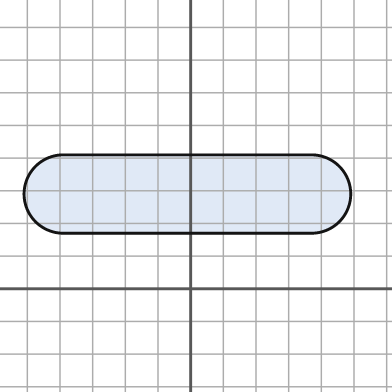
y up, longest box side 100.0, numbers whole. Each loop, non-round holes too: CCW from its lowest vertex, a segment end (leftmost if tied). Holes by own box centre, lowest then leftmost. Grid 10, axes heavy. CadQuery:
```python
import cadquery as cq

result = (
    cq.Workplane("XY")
    .moveTo(-39.0, 17.0)
    .lineTo(37.0, 17.0)
    .threePointArc((49.0, 29.0), (37.0, 41.0))
    .lineTo(-39.0, 41.0)
    .threePointArc((-51.0, 29.0), (-39.0, 17.0))
    .close()
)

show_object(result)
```